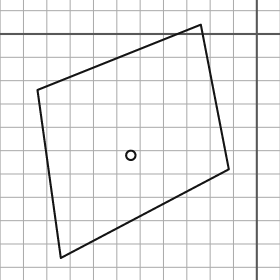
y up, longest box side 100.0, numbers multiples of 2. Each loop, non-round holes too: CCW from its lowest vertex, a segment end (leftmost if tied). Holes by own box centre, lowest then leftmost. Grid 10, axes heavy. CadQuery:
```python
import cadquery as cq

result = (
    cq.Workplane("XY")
    .moveTo(-84.0, -96.0)
    .lineTo(-12.0, -58.0)
    .lineTo(-24.0, 4.0)
    .lineTo(-94.0, -24.0)
    .close()
    .moveTo(-54.0, -52.0)
    .circle(2.0)
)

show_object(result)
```